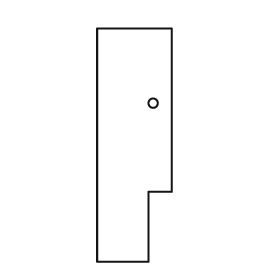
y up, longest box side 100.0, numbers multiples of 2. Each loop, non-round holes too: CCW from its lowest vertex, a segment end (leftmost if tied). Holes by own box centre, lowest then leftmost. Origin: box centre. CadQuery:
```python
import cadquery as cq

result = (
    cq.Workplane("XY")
    .moveTo(-16.0, -50.0)
    .lineTo(6.0, -50.0)
    .lineTo(6.0, -20.0)
    .lineTo(16.0, -20.0)
    .lineTo(16.0, 50.0)
    .lineTo(-16.0, 50.0)
    .close()
    .moveTo(8.0, 18.0)
    .circle(2.0)
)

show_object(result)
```